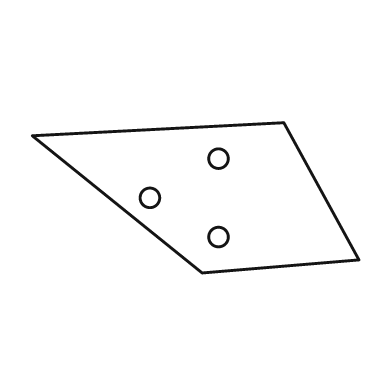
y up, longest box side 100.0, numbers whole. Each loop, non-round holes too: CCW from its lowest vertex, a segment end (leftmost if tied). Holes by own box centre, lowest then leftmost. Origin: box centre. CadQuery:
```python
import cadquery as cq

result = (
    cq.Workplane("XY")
    .moveTo(2.0, -23.0)
    .lineTo(50.0, -19.0)
    .lineTo(27.0, 23.0)
    .lineTo(-50.0, 19.0)
    .close()
    .moveTo(7.0, -12.0)
    .circle(3.0)
    .moveTo(-14.0, 0.0)
    .circle(3.0)
    .moveTo(7.0, 12.0)
    .circle(3.0)
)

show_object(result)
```